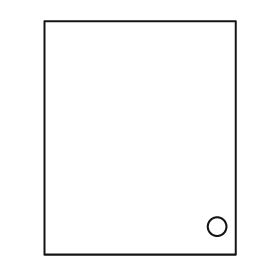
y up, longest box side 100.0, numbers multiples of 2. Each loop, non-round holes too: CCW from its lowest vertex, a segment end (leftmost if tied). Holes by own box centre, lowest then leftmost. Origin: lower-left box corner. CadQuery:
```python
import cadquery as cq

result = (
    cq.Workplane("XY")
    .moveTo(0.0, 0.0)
    .lineTo(82.0, 0.0)
    .lineTo(82.0, 100.0)
    .lineTo(0.0, 100.0)
    .close()
    .moveTo(74.0, 12.0)
    .circle(4.0)
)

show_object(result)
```